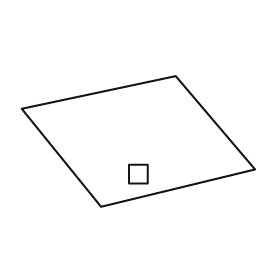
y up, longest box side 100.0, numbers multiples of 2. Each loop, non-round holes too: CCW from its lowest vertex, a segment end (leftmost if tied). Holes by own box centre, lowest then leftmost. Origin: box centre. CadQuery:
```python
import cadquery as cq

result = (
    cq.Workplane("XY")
    .moveTo(-16.0, -28.0)
    .lineTo(50.0, -12.0)
    .lineTo(16.0, 28.0)
    .lineTo(-50.0, 14.0)
    .close()
    .moveTo(-4.0, -18.0)
    .lineTo(4.0, -18.0)
    .lineTo(4.0, -10.0)
    .lineTo(-4.0, -10.0)
    .close()
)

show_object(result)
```